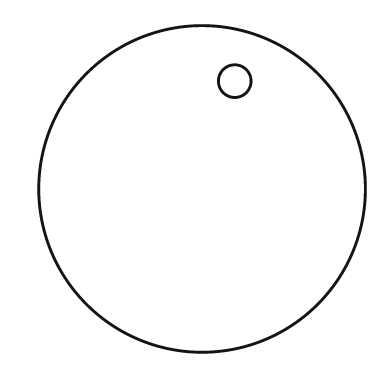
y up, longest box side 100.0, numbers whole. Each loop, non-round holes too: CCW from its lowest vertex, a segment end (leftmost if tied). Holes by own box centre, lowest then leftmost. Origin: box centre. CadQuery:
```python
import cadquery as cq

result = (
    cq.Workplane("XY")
    .moveTo(0.0, 0.0)
    .circle(50.0)
    .moveTo(10.0, 33.0)
    .circle(5.0)
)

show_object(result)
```